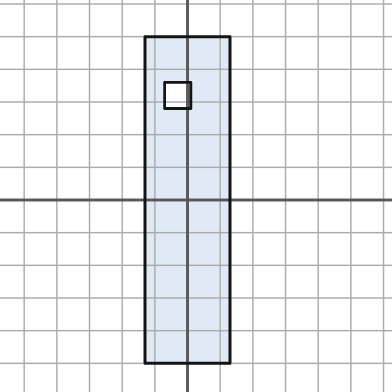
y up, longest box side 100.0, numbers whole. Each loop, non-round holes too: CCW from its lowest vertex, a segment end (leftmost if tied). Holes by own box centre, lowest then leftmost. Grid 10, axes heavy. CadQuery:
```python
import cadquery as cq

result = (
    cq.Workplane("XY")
    .moveTo(-13.0, -50.0)
    .lineTo(13.0, -50.0)
    .lineTo(13.0, 50.0)
    .lineTo(-13.0, 50.0)
    .close()
    .moveTo(-7.0, 28.0)
    .lineTo(1.0, 28.0)
    .lineTo(1.0, 36.0)
    .lineTo(-7.0, 36.0)
    .close()
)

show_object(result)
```